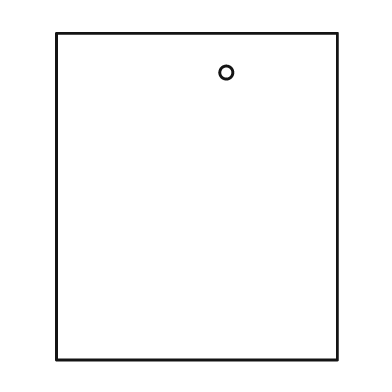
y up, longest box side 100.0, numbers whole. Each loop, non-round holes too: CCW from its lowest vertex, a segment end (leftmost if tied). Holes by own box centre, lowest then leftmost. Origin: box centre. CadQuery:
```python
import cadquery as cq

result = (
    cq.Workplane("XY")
    .moveTo(-43.0, -50.0)
    .lineTo(43.0, -50.0)
    .lineTo(43.0, 50.0)
    .lineTo(-43.0, 50.0)
    .close()
    .moveTo(9.0, 38.0)
    .circle(2.0)
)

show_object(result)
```